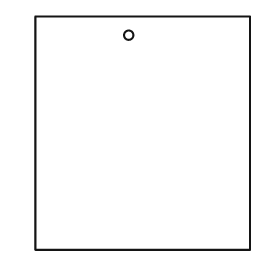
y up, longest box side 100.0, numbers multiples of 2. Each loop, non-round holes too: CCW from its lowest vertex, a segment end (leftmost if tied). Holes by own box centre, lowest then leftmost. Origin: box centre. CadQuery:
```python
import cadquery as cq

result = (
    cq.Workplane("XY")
    .moveTo(-46.0, -50.0)
    .lineTo(46.0, -50.0)
    .lineTo(46.0, 50.0)
    .lineTo(-46.0, 50.0)
    .close()
    .moveTo(-6.0, 42.0)
    .circle(2.0)
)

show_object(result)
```